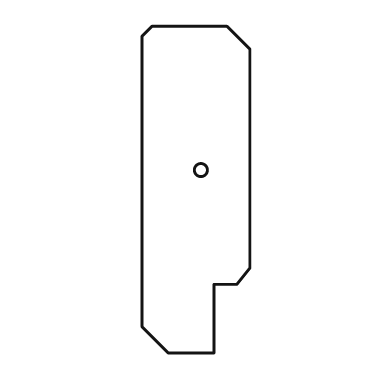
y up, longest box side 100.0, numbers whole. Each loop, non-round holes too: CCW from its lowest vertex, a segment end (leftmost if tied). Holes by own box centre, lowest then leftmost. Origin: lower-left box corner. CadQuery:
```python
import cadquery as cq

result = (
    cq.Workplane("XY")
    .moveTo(8.0, 0.0)
    .lineTo(22.0, 0.0)
    .lineTo(22.0, 21.0)
    .lineTo(29.0, 21.0)
    .lineTo(33.0, 26.0)
    .lineTo(33.0, 93.0)
    .lineTo(26.0, 100.0)
    .lineTo(3.0, 100.0)
    .lineTo(0.0, 97.0)
    .lineTo(0.0, 8.0)
    .close()
    .moveTo(18.0, 56.0)
    .circle(2.0)
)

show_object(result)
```